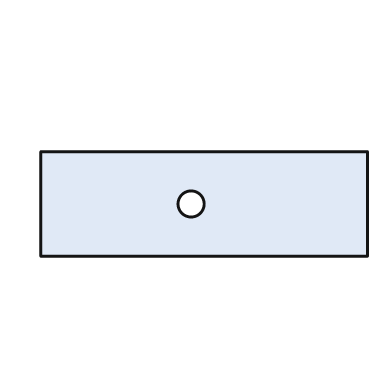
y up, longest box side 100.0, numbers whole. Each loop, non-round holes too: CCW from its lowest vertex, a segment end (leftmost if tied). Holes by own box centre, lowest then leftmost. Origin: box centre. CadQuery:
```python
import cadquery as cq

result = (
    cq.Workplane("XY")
    .moveTo(-50.0, -16.0)
    .lineTo(50.0, -16.0)
    .lineTo(50.0, 16.0)
    .lineTo(-50.0, 16.0)
    .close()
    .moveTo(-4.0, 0.0)
    .circle(4.0)
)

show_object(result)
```